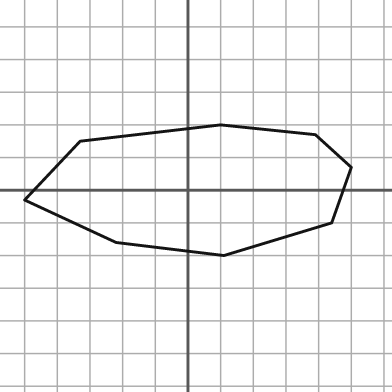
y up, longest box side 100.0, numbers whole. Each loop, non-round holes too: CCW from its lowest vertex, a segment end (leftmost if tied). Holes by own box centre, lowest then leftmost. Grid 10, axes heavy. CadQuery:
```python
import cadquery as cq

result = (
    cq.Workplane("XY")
    .moveTo(11.0, -20.0)
    .lineTo(44.0, -10.0)
    .lineTo(50.0, 7.0)
    .lineTo(39.0, 17.0)
    .lineTo(10.0, 20.0)
    .lineTo(-33.0, 15.0)
    .lineTo(-50.0, -3.0)
    .lineTo(-22.0, -16.0)
    .close()
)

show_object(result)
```